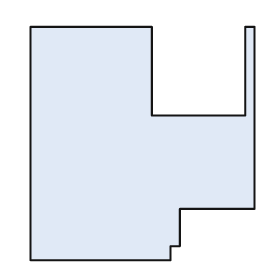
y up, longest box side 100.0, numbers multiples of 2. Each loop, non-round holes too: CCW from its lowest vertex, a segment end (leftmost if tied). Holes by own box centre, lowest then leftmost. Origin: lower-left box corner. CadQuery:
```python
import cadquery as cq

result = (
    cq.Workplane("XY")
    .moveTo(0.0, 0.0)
    .lineTo(60.0, 0.0)
    .lineTo(60.0, 6.0)
    .lineTo(64.0, 6.0)
    .lineTo(64.0, 22.0)
    .lineTo(96.0, 22.0)
    .lineTo(96.0, 100.0)
    .lineTo(92.0, 100.0)
    .lineTo(92.0, 62.0)
    .lineTo(52.0, 62.0)
    .lineTo(52.0, 100.0)
    .lineTo(0.0, 100.0)
    .close()
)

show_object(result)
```